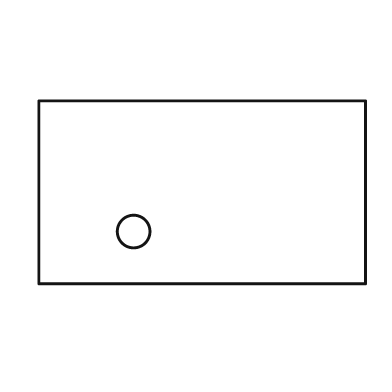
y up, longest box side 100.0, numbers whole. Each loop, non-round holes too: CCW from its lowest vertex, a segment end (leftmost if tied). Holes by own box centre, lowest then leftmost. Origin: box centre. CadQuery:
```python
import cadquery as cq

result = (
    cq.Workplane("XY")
    .moveTo(-50.0, -28.0)
    .lineTo(50.0, -28.0)
    .lineTo(50.0, 28.0)
    .lineTo(-50.0, 28.0)
    .close()
    .moveTo(-21.0, -12.0)
    .circle(5.0)
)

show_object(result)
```